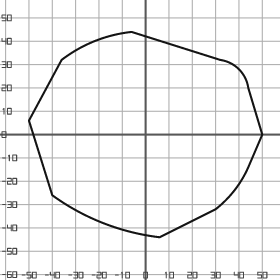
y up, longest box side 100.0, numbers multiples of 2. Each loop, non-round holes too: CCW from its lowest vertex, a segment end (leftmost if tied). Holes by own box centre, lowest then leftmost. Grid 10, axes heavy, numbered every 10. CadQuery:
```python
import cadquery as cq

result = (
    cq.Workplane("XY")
    .moveTo(6.0, -44.0)
    .lineTo(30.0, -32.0)
    .threePointArc((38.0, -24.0), (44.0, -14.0))
    .lineTo(50.0, 0.0)
    .lineTo(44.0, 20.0)
    .threePointArc((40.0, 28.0), (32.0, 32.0))
    .lineTo(-6.0, 44.0)
    .threePointArc((-22.0, 40.0), (-36.0, 32.0))
    .lineTo(-50.0, 6.0)
    .lineTo(-40.0, -26.0)
    .threePointArc((-18.0, -38.0), (6.0, -44.0))
    .close()
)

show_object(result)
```